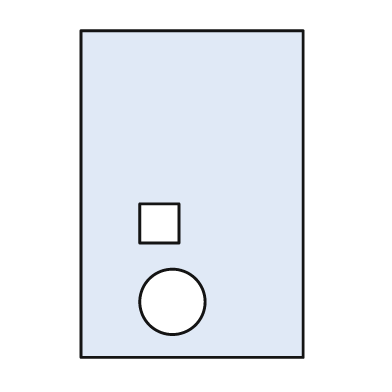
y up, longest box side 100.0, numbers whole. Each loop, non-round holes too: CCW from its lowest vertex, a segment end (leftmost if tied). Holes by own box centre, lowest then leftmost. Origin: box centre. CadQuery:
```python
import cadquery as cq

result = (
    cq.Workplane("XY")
    .moveTo(-34.0, -50.0)
    .lineTo(34.0, -50.0)
    .lineTo(34.0, 50.0)
    .lineTo(-34.0, 50.0)
    .close()
    .moveTo(-6.0, -33.0)
    .circle(10.0)
    .moveTo(-16.0, -15.0)
    .lineTo(-4.0, -15.0)
    .lineTo(-4.0, -3.0)
    .lineTo(-16.0, -3.0)
    .close()
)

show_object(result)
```